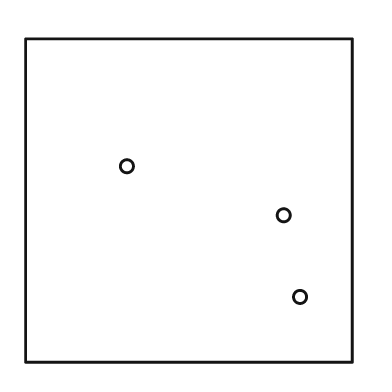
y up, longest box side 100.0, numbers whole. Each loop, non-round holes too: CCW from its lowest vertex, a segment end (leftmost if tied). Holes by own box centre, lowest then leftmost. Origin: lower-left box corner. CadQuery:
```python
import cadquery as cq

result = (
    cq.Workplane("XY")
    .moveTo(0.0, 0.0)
    .lineTo(100.0, 0.0)
    .lineTo(100.0, 99.0)
    .lineTo(0.0, 99.0)
    .close()
    .moveTo(84.0, 20.0)
    .circle(2.0)
    .moveTo(79.0, 45.0)
    .circle(2.0)
    .moveTo(31.0, 60.0)
    .circle(2.0)
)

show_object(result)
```